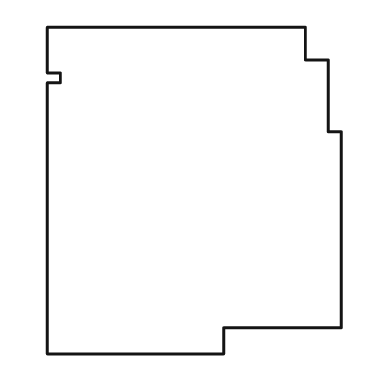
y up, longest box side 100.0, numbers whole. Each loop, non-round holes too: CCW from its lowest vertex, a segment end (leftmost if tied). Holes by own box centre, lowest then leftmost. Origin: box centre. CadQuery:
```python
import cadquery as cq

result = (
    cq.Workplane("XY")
    .moveTo(-45.0, -50.0)
    .lineTo(9.0, -50.0)
    .lineTo(9.0, -42.0)
    .lineTo(45.0, -42.0)
    .lineTo(45.0, 18.0)
    .lineTo(41.0, 18.0)
    .lineTo(41.0, 40.0)
    .lineTo(34.0, 40.0)
    .lineTo(34.0, 50.0)
    .lineTo(-45.0, 50.0)
    .lineTo(-45.0, 36.0)
    .lineTo(-41.0, 36.0)
    .lineTo(-41.0, 33.0)
    .lineTo(-45.0, 33.0)
    .close()
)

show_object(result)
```